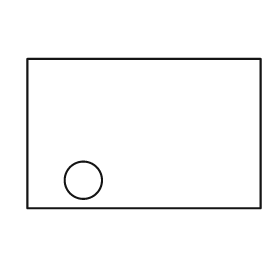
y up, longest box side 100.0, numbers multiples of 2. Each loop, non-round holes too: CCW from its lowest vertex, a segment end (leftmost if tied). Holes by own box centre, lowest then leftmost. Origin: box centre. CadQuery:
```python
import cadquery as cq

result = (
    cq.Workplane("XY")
    .moveTo(-50.0, -32.0)
    .lineTo(50.0, -32.0)
    .lineTo(50.0, 32.0)
    .lineTo(-50.0, 32.0)
    .close()
    .moveTo(-26.0, -20.0)
    .circle(8.0)
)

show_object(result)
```